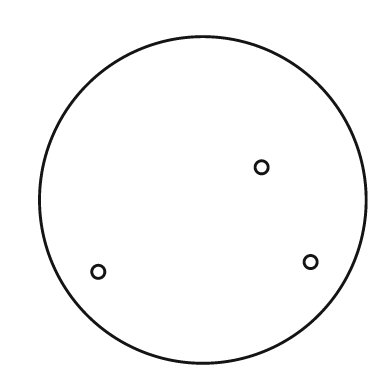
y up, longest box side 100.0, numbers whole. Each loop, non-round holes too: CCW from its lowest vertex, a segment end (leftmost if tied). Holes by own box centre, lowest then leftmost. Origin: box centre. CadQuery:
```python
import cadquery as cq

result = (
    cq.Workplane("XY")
    .moveTo(0.0, 0.0)
    .circle(50.0)
    .moveTo(-32.0, -22.0)
    .circle(2.0)
    .moveTo(33.0, -19.0)
    .circle(2.0)
    .moveTo(18.0, 10.0)
    .circle(2.0)
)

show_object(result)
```